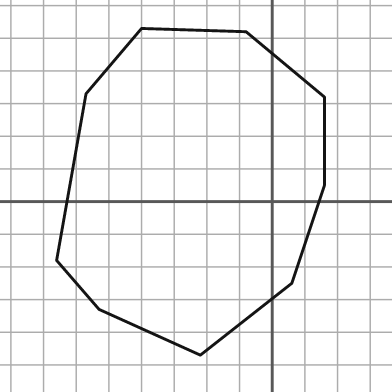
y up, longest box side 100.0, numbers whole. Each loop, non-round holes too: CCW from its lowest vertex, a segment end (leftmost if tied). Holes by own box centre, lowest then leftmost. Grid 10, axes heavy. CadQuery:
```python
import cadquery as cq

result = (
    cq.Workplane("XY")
    .moveTo(-22.0, -47.0)
    .lineTo(6.0, -25.0)
    .lineTo(16.0, 5.0)
    .lineTo(16.0, 32.0)
    .lineTo(-8.0, 52.0)
    .lineTo(-40.0, 53.0)
    .lineTo(-57.0, 33.0)
    .lineTo(-66.0, -18.0)
    .lineTo(-53.0, -33.0)
    .close()
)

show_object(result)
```